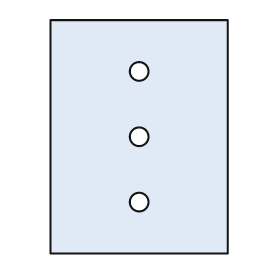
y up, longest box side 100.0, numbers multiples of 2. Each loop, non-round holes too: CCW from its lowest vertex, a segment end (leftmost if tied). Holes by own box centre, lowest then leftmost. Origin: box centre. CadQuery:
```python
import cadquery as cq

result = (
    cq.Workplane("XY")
    .moveTo(-38.0, -50.0)
    .lineTo(38.0, -50.0)
    .lineTo(38.0, 50.0)
    .lineTo(-38.0, 50.0)
    .close()
    .moveTo(0.0, -28.0)
    .circle(4.0)
    .moveTo(0.0, 0.0)
    .circle(4.0)
    .moveTo(0.0, 28.0)
    .circle(4.0)
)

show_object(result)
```